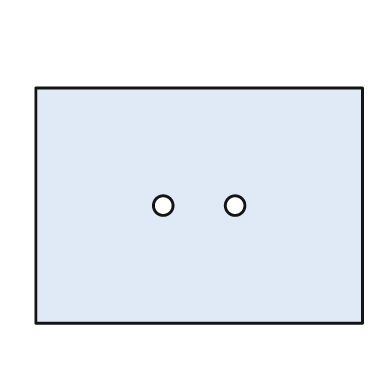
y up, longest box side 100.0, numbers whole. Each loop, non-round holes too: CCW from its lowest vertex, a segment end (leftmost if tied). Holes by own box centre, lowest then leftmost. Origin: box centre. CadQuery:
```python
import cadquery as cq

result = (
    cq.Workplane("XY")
    .moveTo(-50.0, -36.0)
    .lineTo(50.0, -36.0)
    .lineTo(50.0, 36.0)
    .lineTo(-50.0, 36.0)
    .close()
    .moveTo(-11.0, 0.0)
    .circle(3.0)
    .moveTo(11.0, 0.0)
    .circle(3.0)
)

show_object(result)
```